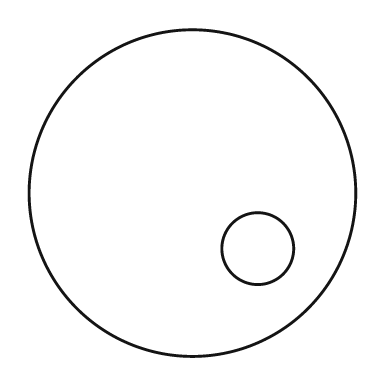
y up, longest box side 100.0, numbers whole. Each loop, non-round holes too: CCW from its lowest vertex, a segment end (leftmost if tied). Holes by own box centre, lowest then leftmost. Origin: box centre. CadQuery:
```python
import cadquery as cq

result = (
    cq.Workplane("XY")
    .moveTo(0.0, 0.0)
    .circle(50.0)
    .moveTo(20.0, -17.0)
    .circle(11.0)
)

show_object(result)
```